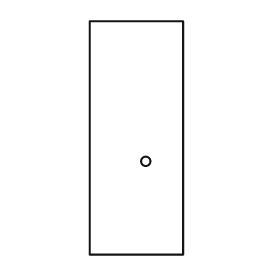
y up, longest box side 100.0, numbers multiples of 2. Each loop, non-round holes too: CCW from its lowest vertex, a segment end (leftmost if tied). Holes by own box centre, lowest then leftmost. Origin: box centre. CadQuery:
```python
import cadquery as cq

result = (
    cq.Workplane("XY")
    .moveTo(-20.0, -50.0)
    .lineTo(20.0, -50.0)
    .lineTo(20.0, 50.0)
    .lineTo(-20.0, 50.0)
    .close()
    .moveTo(4.0, -10.0)
    .circle(2.0)
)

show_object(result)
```